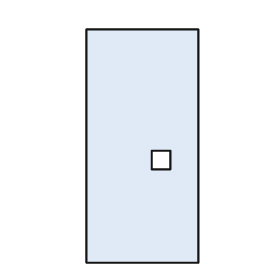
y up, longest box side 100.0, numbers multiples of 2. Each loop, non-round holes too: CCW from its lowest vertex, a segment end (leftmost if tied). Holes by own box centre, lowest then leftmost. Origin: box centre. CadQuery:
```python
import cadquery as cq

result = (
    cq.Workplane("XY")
    .moveTo(-24.0, -50.0)
    .lineTo(24.0, -50.0)
    .lineTo(24.0, 50.0)
    .lineTo(-24.0, 50.0)
    .close()
    .moveTo(4.0, -10.0)
    .lineTo(12.0, -10.0)
    .lineTo(12.0, -2.0)
    .lineTo(4.0, -2.0)
    .close()
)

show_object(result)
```